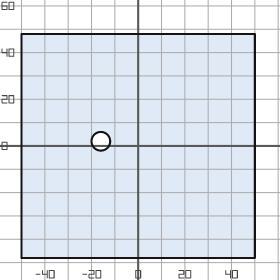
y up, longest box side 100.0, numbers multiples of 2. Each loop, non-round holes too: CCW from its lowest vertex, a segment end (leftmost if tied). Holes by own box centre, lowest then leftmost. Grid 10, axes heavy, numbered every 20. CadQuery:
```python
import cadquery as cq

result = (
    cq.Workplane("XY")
    .moveTo(-50.0, -48.0)
    .lineTo(50.0, -48.0)
    .lineTo(50.0, 48.0)
    .lineTo(-50.0, 48.0)
    .close()
    .moveTo(-16.0, 2.0)
    .circle(4.0)
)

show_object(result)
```